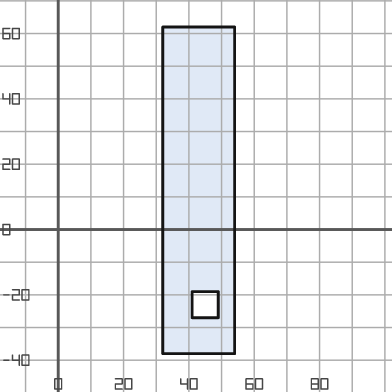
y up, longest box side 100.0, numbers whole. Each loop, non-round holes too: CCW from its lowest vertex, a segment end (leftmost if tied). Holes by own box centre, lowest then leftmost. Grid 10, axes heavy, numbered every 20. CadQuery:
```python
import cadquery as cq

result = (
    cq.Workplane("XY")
    .moveTo(32.0, -38.0)
    .lineTo(54.0, -38.0)
    .lineTo(54.0, 62.0)
    .lineTo(32.0, 62.0)
    .close()
    .moveTo(41.0, -27.0)
    .lineTo(49.0, -27.0)
    .lineTo(49.0, -19.0)
    .lineTo(41.0, -19.0)
    .close()
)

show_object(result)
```